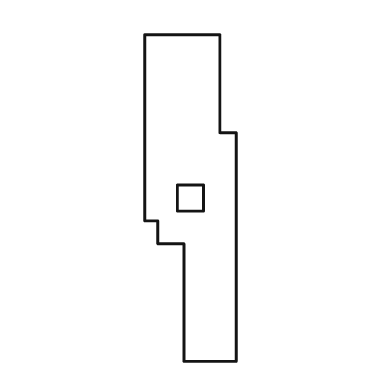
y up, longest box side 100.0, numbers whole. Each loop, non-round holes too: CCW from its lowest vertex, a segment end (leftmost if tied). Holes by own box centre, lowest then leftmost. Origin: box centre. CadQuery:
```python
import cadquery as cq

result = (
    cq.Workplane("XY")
    .moveTo(-2.0, -50.0)
    .lineTo(14.0, -50.0)
    .lineTo(14.0, 20.0)
    .lineTo(9.0, 20.0)
    .lineTo(9.0, 50.0)
    .lineTo(-14.0, 50.0)
    .lineTo(-14.0, -7.0)
    .lineTo(-10.0, -7.0)
    .lineTo(-10.0, -14.0)
    .lineTo(-2.0, -14.0)
    .close()
    .moveTo(-4.0, -4.0)
    .lineTo(4.0, -4.0)
    .lineTo(4.0, 4.0)
    .lineTo(-4.0, 4.0)
    .close()
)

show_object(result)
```